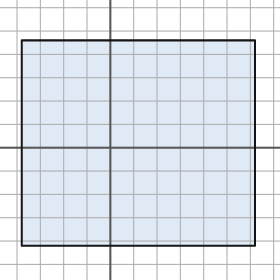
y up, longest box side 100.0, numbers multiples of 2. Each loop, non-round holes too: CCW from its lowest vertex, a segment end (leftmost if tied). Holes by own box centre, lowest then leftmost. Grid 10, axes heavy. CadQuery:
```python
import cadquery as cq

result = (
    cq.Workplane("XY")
    .moveTo(-38.0, -42.0)
    .lineTo(62.0, -42.0)
    .lineTo(62.0, 46.0)
    .lineTo(-38.0, 46.0)
    .close()
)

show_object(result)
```